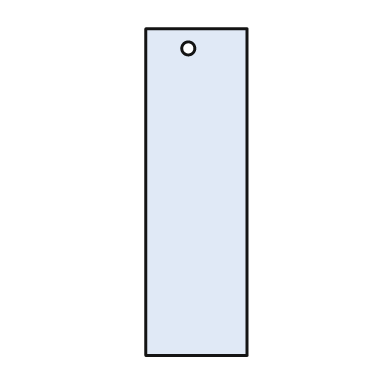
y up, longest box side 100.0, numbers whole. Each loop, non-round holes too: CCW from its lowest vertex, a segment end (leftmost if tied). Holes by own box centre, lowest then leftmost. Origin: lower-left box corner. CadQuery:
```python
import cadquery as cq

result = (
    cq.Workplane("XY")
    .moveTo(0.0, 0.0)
    .lineTo(31.0, 0.0)
    .lineTo(31.0, 100.0)
    .lineTo(0.0, 100.0)
    .close()
    .moveTo(13.0, 94.0)
    .circle(2.0)
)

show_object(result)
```